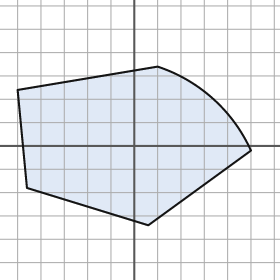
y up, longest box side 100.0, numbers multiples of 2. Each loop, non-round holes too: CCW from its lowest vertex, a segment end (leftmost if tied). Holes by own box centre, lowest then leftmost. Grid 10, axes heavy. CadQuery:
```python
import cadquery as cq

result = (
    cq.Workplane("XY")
    .moveTo(6.0, -34.0)
    .lineTo(50.0, -2.0)
    .threePointArc((34.0, 20.0), (10.0, 34.0))
    .lineTo(-50.0, 24.0)
    .lineTo(-46.0, -18.0)
    .close()
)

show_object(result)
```